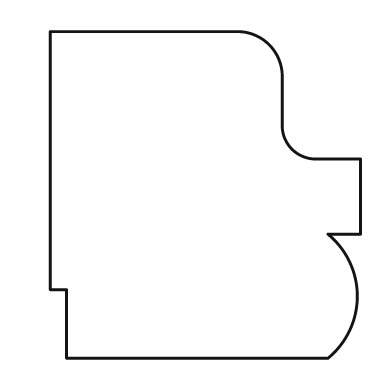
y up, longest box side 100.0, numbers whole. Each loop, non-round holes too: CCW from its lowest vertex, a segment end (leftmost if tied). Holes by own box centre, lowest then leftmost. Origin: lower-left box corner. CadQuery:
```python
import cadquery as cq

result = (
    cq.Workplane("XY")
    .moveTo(5.0, 0.0)
    .lineTo(85.0, 0.0)
    .threePointArc((94.0, 19.0), (85.0, 38.0))
    .lineTo(95.0, 38.0)
    .lineTo(95.0, 61.0)
    .lineTo(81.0, 61.0)
    .threePointArc((74.0, 64.0), (71.0, 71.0))
    .lineTo(71.0, 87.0)
    .threePointArc((67.0, 96.0), (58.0, 100.0))
    .lineTo(0.0, 100.0)
    .lineTo(0.0, 21.0)
    .lineTo(5.0, 21.0)
    .close()
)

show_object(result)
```